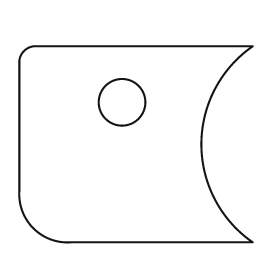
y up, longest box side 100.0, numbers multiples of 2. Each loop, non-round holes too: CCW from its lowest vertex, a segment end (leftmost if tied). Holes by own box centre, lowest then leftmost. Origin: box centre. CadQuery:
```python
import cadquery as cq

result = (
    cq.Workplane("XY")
    .moveTo(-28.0, -42.0)
    .lineTo(50.0, -42.0)
    .threePointArc((28.0, 0.0), (50.0, 42.0))
    .lineTo(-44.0, 42.0)
    .threePointArc((-48.0, 40.0), (-50.0, 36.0))
    .lineTo(-50.0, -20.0)
    .threePointArc((-44.0, -36.0), (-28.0, -42.0))
    .close()
    .moveTo(-6.0, 18.0)
    .circle(10.0)
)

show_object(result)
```